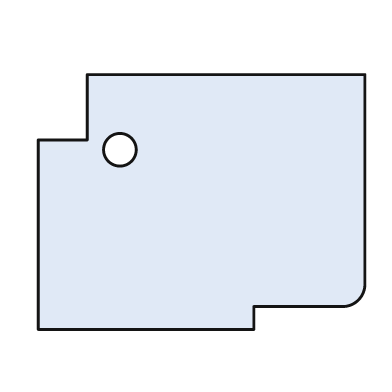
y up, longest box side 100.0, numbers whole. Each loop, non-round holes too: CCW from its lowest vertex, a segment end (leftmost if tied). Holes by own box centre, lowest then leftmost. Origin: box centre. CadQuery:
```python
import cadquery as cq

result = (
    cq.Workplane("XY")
    .moveTo(-50.0, -39.0)
    .lineTo(16.0, -39.0)
    .lineTo(16.0, -32.0)
    .lineTo(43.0, -32.0)
    .threePointArc((48.0, -30.0), (50.0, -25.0))
    .lineTo(50.0, 39.0)
    .lineTo(-35.0, 39.0)
    .lineTo(-35.0, 19.0)
    .lineTo(-50.0, 19.0)
    .close()
    .moveTo(-25.0, 16.0)
    .circle(5.0)
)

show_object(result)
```